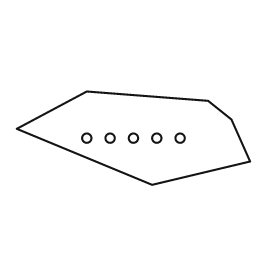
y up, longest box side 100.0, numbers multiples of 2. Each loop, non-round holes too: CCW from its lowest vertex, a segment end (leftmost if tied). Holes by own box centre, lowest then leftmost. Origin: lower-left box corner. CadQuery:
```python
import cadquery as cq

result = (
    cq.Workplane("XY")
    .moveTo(58.0, 0.0)
    .lineTo(100.0, 10.0)
    .lineTo(92.0, 28.0)
    .lineTo(82.0, 36.0)
    .lineTo(30.0, 40.0)
    .lineTo(0.0, 24.0)
    .close()
    .moveTo(30.0, 20.0)
    .circle(2.0)
    .moveTo(40.0, 20.0)
    .circle(2.0)
    .moveTo(50.0, 20.0)
    .circle(2.0)
    .moveTo(60.0, 20.0)
    .circle(2.0)
    .moveTo(70.0, 20.0)
    .circle(2.0)
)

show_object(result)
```